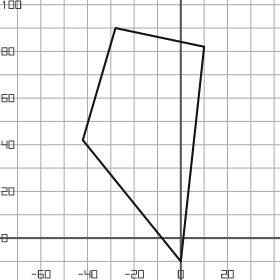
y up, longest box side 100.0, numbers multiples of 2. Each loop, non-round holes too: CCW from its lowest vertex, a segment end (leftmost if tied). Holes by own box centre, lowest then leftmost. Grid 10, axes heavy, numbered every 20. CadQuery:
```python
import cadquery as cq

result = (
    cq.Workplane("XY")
    .moveTo(0.0, -10.0)
    .lineTo(10.0, 82.0)
    .lineTo(-28.0, 90.0)
    .lineTo(-42.0, 42.0)
    .close()
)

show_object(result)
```